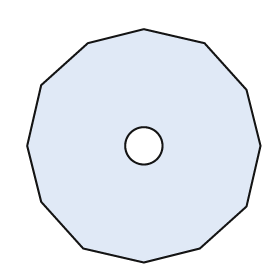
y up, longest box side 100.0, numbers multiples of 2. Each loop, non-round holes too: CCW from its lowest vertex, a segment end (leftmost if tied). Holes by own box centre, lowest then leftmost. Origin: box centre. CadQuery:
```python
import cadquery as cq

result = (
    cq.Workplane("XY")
    .moveTo(0.0, -50.0)
    .lineTo(24.0, -44.0)
    .lineTo(44.0, -26.0)
    .lineTo(50.0, 0.0)
    .lineTo(44.0, 24.0)
    .lineTo(26.0, 44.0)
    .lineTo(0.0, 50.0)
    .lineTo(-24.0, 44.0)
    .lineTo(-44.0, 26.0)
    .lineTo(-50.0, 0.0)
    .lineTo(-44.0, -24.0)
    .lineTo(-26.0, -44.0)
    .close()
    .moveTo(0.0, 0.0)
    .circle(8.0)
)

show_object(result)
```